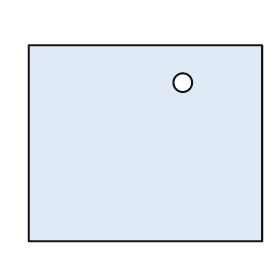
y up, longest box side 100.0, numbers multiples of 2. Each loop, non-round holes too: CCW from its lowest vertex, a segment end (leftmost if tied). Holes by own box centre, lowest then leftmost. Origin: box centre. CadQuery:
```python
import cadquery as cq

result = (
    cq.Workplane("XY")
    .moveTo(-50.0, -42.0)
    .lineTo(50.0, -42.0)
    .lineTo(50.0, 42.0)
    .lineTo(-50.0, 42.0)
    .close()
    .moveTo(16.0, 26.0)
    .circle(4.0)
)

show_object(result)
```